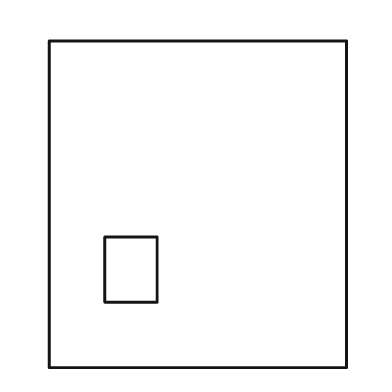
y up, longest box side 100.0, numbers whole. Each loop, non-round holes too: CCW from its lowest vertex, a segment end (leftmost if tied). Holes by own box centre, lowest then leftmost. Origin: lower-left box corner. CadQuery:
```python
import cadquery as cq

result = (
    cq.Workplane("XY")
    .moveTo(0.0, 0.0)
    .lineTo(91.0, 0.0)
    .lineTo(91.0, 100.0)
    .lineTo(0.0, 100.0)
    .close()
    .moveTo(17.0, 20.0)
    .lineTo(33.0, 20.0)
    .lineTo(33.0, 40.0)
    .lineTo(17.0, 40.0)
    .close()
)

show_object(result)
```